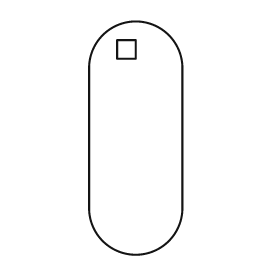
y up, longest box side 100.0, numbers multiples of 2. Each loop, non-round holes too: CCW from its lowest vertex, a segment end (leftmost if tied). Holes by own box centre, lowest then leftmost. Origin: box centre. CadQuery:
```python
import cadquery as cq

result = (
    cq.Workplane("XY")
    .moveTo(-20.0, -30.0)
    .threePointArc((0.0, -50.0), (20.0, -30.0))
    .lineTo(20.0, 30.0)
    .threePointArc((0.0, 50.0), (-20.0, 30.0))
    .close()
    .moveTo(-8.0, 34.0)
    .lineTo(0.0, 34.0)
    .lineTo(0.0, 42.0)
    .lineTo(-8.0, 42.0)
    .close()
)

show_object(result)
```